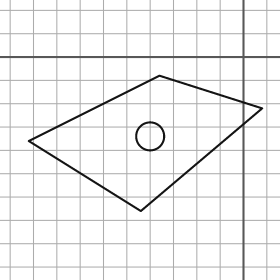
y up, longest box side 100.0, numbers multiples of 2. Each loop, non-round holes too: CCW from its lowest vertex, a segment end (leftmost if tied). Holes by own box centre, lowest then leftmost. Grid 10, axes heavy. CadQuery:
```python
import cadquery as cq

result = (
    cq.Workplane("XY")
    .moveTo(-44.0, -66.0)
    .lineTo(8.0, -22.0)
    .lineTo(-36.0, -8.0)
    .lineTo(-92.0, -36.0)
    .close()
    .moveTo(-40.0, -34.0)
    .circle(6.0)
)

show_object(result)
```